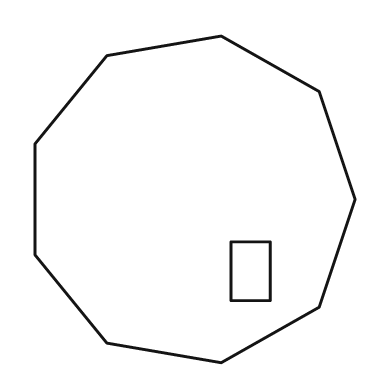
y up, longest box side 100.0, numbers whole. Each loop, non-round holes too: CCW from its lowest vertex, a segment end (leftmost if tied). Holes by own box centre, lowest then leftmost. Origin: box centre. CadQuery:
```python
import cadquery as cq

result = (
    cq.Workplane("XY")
    .moveTo(8.0, -50.0)
    .lineTo(38.0, -33.0)
    .lineTo(49.0, 0.0)
    .lineTo(38.0, 33.0)
    .lineTo(8.0, 50.0)
    .lineTo(-27.0, 44.0)
    .lineTo(-49.0, 17.0)
    .lineTo(-49.0, -17.0)
    .lineTo(-27.0, -44.0)
    .close()
    .moveTo(11.0, -31.0)
    .lineTo(23.0, -31.0)
    .lineTo(23.0, -13.0)
    .lineTo(11.0, -13.0)
    .close()
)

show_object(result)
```